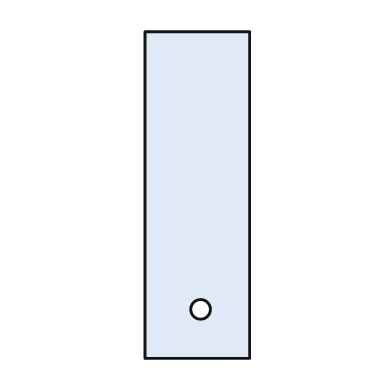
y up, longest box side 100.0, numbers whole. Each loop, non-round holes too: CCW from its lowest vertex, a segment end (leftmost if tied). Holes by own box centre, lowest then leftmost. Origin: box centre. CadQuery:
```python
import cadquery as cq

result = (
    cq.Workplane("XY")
    .moveTo(-16.0, -50.0)
    .lineTo(16.0, -50.0)
    .lineTo(16.0, 50.0)
    .lineTo(-16.0, 50.0)
    .close()
    .moveTo(1.0, -35.0)
    .circle(3.0)
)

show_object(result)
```